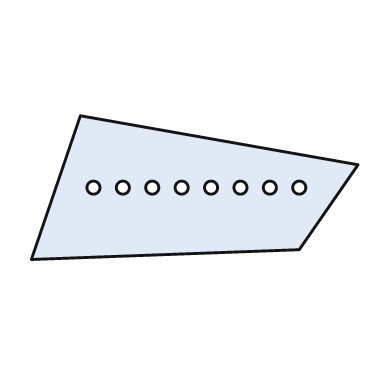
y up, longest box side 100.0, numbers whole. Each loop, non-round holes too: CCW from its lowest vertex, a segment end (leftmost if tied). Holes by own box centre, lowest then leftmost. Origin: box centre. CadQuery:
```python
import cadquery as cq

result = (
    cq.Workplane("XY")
    .moveTo(-50.0, -22.0)
    .lineTo(32.0, -19.0)
    .lineTo(50.0, 7.0)
    .lineTo(-35.0, 22.0)
    .close()
    .moveTo(-31.0, 0.0)
    .circle(2.0)
    .moveTo(-22.0, 0.0)
    .circle(2.0)
    .moveTo(-13.0, 0.0)
    .circle(2.0)
    .moveTo(-4.0, 0.0)
    .circle(2.0)
    .moveTo(5.0, 0.0)
    .circle(2.0)
    .moveTo(14.0, 0.0)
    .circle(2.0)
    .moveTo(23.0, 0.0)
    .circle(2.0)
    .moveTo(32.0, 0.0)
    .circle(2.0)
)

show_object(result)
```